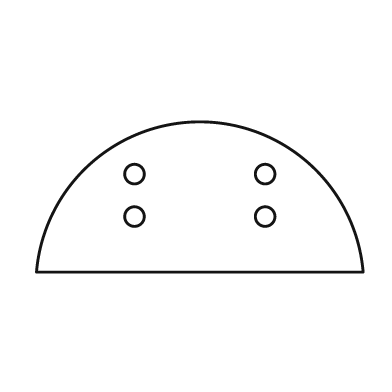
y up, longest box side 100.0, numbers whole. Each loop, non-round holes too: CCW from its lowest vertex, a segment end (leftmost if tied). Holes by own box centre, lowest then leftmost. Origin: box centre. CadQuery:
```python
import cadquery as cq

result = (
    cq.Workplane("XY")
    .moveTo(-50.0, -23.0)
    .lineTo(50.0, -23.0)
    .threePointArc((0.0, 23.0), (-50.0, -23.0))
    .close()
    .moveTo(-20.0, -6.0)
    .circle(3.0)
    .moveTo(20.0, -6.0)
    .circle(3.0)
    .moveTo(-20.0, 7.0)
    .circle(3.0)
    .moveTo(20.0, 7.0)
    .circle(3.0)
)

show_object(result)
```